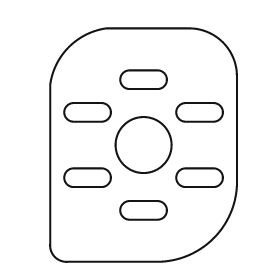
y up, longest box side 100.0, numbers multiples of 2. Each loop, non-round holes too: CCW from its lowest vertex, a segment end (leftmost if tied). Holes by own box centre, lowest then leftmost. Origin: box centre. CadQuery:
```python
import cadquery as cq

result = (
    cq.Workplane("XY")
    .moveTo(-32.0, -50.0)
    .lineTo(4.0, -50.0)
    .threePointArc((30.0, -40.0), (40.0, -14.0))
    .lineTo(40.0, 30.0)
    .threePointArc((34.0, 44.0), (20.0, 50.0))
    .lineTo(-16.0, 50.0)
    .threePointArc((-32.0, 42.0), (-40.0, 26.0))
    .lineTo(-40.0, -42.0)
    .threePointArc((-38.0, -48.0), (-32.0, -50.0))
    .close()
    .moveTo(-6.0, -32.0)
    .lineTo(6.0, -32.0)
    .threePointArc((10.0, -28.0), (6.0, -24.0))
    .lineTo(-6.0, -24.0)
    .threePointArc((-10.0, -28.0), (-6.0, -32.0))
    .close()
    .moveTo(-30.0, -18.0)
    .lineTo(-18.0, -18.0)
    .threePointArc((-14.0, -14.0), (-18.0, -10.0))
    .lineTo(-30.0, -10.0)
    .threePointArc((-34.0, -14.0), (-30.0, -18.0))
    .close()
    .moveTo(18.0, -18.0)
    .lineTo(30.0, -18.0)
    .threePointArc((34.0, -14.0), (30.0, -10.0))
    .lineTo(18.0, -10.0)
    .threePointArc((14.0, -14.0), (18.0, -18.0))
    .close()
    .moveTo(0.0, 0.0)
    .circle(12.0)
    .moveTo(-30.0, 10.0)
    .lineTo(-18.0, 10.0)
    .threePointArc((-14.0, 14.0), (-18.0, 18.0))
    .lineTo(-30.0, 18.0)
    .threePointArc((-34.0, 14.0), (-30.0, 10.0))
    .close()
    .moveTo(18.0, 10.0)
    .lineTo(30.0, 10.0)
    .threePointArc((34.0, 14.0), (30.0, 18.0))
    .lineTo(18.0, 18.0)
    .threePointArc((14.0, 14.0), (18.0, 10.0))
    .close()
    .moveTo(-6.0, 24.0)
    .lineTo(6.0, 24.0)
    .threePointArc((10.0, 28.0), (6.0, 32.0))
    .lineTo(-6.0, 32.0)
    .threePointArc((-10.0, 28.0), (-6.0, 24.0))
    .close()
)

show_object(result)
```